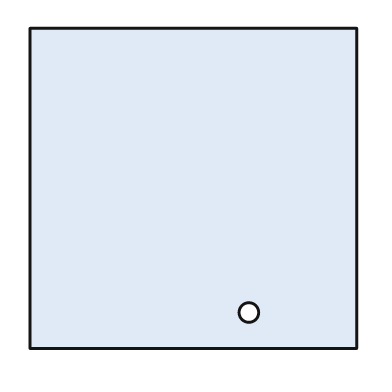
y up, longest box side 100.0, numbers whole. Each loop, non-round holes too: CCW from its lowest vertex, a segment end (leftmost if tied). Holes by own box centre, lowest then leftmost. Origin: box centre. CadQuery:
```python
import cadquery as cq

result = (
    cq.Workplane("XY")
    .moveTo(-50.0, -49.0)
    .lineTo(50.0, -49.0)
    .lineTo(50.0, 49.0)
    .lineTo(-50.0, 49.0)
    .close()
    .moveTo(17.0, -38.0)
    .circle(3.0)
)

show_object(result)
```